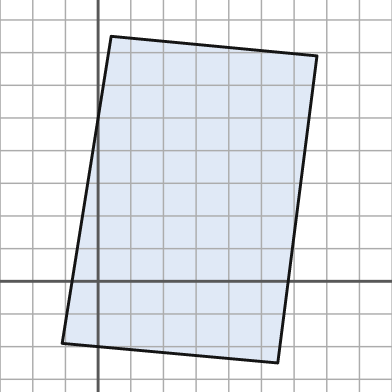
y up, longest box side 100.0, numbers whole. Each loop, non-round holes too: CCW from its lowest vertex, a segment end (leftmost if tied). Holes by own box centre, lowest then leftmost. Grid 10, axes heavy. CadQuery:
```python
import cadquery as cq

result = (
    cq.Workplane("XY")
    .moveTo(55.0, -25.0)
    .lineTo(67.0, 69.0)
    .lineTo(4.0, 75.0)
    .lineTo(-11.0, -19.0)
    .close()
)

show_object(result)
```